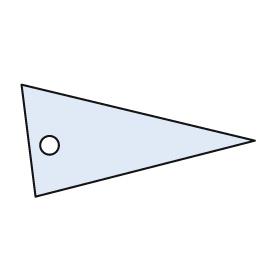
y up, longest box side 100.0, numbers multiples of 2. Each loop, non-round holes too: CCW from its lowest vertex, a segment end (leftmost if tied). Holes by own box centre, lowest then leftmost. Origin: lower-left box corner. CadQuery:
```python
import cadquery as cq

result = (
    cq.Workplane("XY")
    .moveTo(6.0, 0.0)
    .lineTo(100.0, 24.0)
    .lineTo(0.0, 48.0)
    .close()
    .moveTo(12.0, 22.0)
    .circle(4.0)
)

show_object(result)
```